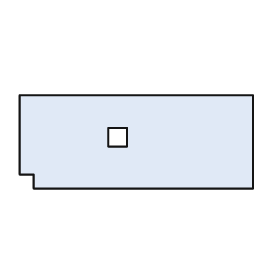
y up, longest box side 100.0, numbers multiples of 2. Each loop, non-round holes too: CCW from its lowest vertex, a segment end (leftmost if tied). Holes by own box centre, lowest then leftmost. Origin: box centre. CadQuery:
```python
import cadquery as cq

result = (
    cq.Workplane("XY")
    .moveTo(-44.0, -20.0)
    .lineTo(50.0, -20.0)
    .lineTo(50.0, 20.0)
    .lineTo(-50.0, 20.0)
    .lineTo(-50.0, -14.0)
    .lineTo(-44.0, -14.0)
    .close()
    .moveTo(-12.0, -2.0)
    .lineTo(-4.0, -2.0)
    .lineTo(-4.0, 6.0)
    .lineTo(-12.0, 6.0)
    .close()
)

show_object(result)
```